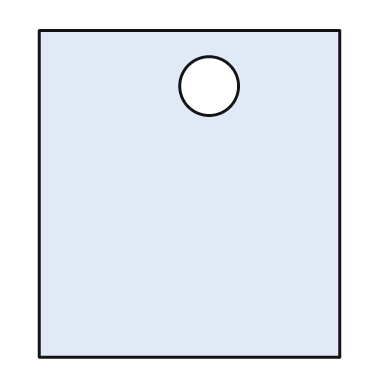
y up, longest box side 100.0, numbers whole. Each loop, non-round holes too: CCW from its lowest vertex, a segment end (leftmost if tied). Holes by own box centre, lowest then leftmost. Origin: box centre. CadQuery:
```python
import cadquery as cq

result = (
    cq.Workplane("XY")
    .moveTo(-46.0, -50.0)
    .lineTo(46.0, -50.0)
    .lineTo(46.0, 50.0)
    .lineTo(-46.0, 50.0)
    .close()
    .moveTo(6.0, 33.0)
    .circle(9.0)
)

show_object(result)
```